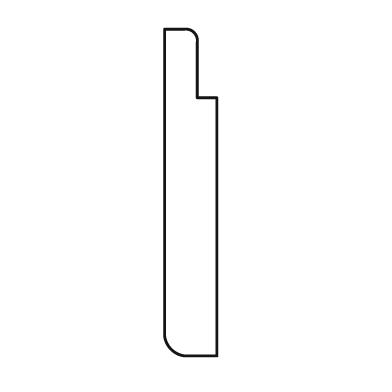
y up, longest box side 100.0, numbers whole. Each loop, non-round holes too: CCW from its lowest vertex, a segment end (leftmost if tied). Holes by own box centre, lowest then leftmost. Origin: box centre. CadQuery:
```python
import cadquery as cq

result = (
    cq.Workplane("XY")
    .moveTo(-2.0, -50.0)
    .lineTo(8.0, -50.0)
    .lineTo(8.0, 29.0)
    .lineTo(2.0, 29.0)
    .lineTo(2.0, 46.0)
    .threePointArc((1.0, 49.0), (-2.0, 50.0))
    .lineTo(-8.0, 50.0)
    .lineTo(-8.0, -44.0)
    .threePointArc((-6.0, -48.0), (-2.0, -50.0))
    .close()
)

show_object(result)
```